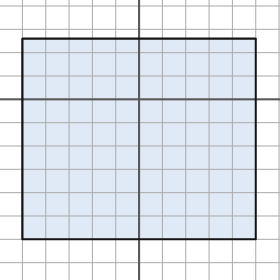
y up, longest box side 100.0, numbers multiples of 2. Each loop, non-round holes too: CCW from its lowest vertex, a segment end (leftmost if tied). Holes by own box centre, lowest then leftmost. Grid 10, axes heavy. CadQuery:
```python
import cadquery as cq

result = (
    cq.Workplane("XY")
    .moveTo(-50.0, -60.0)
    .lineTo(50.0, -60.0)
    .lineTo(50.0, 26.0)
    .lineTo(-50.0, 26.0)
    .close()
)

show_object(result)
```